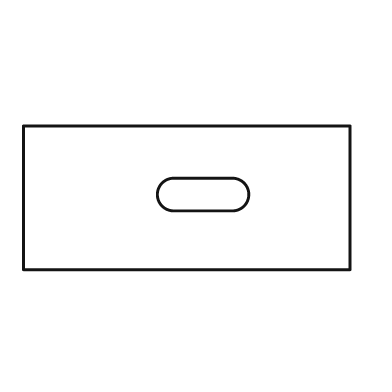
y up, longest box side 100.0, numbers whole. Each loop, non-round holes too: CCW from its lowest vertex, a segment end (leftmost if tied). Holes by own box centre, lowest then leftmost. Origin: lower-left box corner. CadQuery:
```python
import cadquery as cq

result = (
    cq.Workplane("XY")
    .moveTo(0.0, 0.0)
    .lineTo(100.0, 0.0)
    .lineTo(100.0, 44.0)
    .lineTo(0.0, 44.0)
    .close()
    .moveTo(46.0, 18.0)
    .lineTo(64.0, 18.0)
    .threePointArc((69.0, 23.0), (64.0, 28.0))
    .lineTo(46.0, 28.0)
    .threePointArc((41.0, 23.0), (46.0, 18.0))
    .close()
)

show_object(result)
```